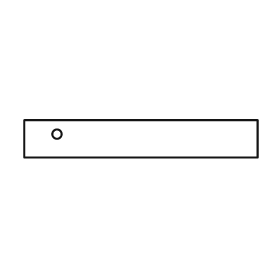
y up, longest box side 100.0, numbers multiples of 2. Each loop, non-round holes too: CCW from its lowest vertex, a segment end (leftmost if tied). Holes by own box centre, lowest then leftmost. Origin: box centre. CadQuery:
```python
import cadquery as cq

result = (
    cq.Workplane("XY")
    .moveTo(-50.0, -8.0)
    .lineTo(50.0, -8.0)
    .lineTo(50.0, 8.0)
    .lineTo(-50.0, 8.0)
    .close()
    .moveTo(-36.0, 2.0)
    .circle(2.0)
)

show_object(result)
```